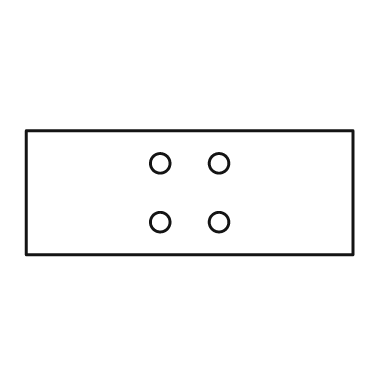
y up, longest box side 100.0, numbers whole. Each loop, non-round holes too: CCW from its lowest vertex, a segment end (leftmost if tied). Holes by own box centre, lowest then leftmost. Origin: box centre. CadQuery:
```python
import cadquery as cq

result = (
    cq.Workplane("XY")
    .moveTo(-50.0, -19.0)
    .lineTo(50.0, -19.0)
    .lineTo(50.0, 19.0)
    .lineTo(-50.0, 19.0)
    .close()
    .moveTo(-9.0, -9.0)
    .circle(3.0)
    .moveTo(9.0, -9.0)
    .circle(3.0)
    .moveTo(-9.0, 9.0)
    .circle(3.0)
    .moveTo(9.0, 9.0)
    .circle(3.0)
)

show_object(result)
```